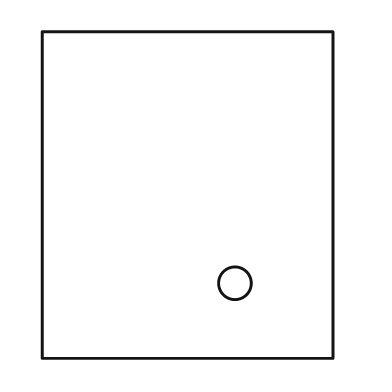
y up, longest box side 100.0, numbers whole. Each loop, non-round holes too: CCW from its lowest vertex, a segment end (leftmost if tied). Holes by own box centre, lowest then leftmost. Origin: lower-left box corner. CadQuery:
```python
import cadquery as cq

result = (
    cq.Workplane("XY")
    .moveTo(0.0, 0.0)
    .lineTo(89.0, 0.0)
    .lineTo(89.0, 100.0)
    .lineTo(0.0, 100.0)
    .close()
    .moveTo(59.0, 23.0)
    .circle(5.0)
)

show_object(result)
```